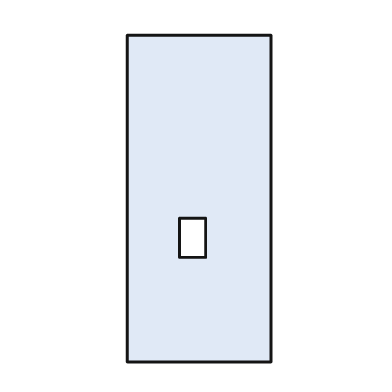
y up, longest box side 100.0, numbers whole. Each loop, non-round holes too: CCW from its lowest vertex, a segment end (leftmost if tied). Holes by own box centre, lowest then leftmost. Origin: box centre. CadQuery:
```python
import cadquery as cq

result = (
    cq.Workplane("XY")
    .moveTo(-22.0, -50.0)
    .lineTo(22.0, -50.0)
    .lineTo(22.0, 50.0)
    .lineTo(-22.0, 50.0)
    .close()
    .moveTo(-6.0, -18.0)
    .lineTo(2.0, -18.0)
    .lineTo(2.0, -6.0)
    .lineTo(-6.0, -6.0)
    .close()
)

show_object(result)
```